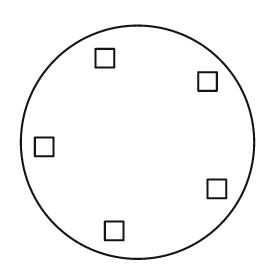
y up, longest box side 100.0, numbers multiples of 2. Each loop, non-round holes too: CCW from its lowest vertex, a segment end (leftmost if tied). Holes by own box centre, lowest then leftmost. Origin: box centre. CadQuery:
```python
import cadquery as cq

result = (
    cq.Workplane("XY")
    .moveTo(0.0, 0.0)
    .circle(50.0)
    .moveTo(-14.0, -42.0)
    .lineTo(-6.0, -42.0)
    .lineTo(-6.0, -34.0)
    .lineTo(-14.0, -34.0)
    .close()
    .moveTo(30.0, -24.0)
    .lineTo(38.0, -24.0)
    .lineTo(38.0, -16.0)
    .lineTo(30.0, -16.0)
    .close()
    .moveTo(-44.0, -6.0)
    .lineTo(-36.0, -6.0)
    .lineTo(-36.0, 2.0)
    .lineTo(-44.0, 2.0)
    .close()
    .moveTo(26.0, 22.0)
    .lineTo(34.0, 22.0)
    .lineTo(34.0, 30.0)
    .lineTo(26.0, 30.0)
    .close()
    .moveTo(-18.0, 32.0)
    .lineTo(-10.0, 32.0)
    .lineTo(-10.0, 40.0)
    .lineTo(-18.0, 40.0)
    .close()
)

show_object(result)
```